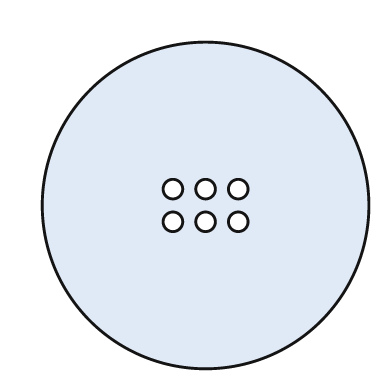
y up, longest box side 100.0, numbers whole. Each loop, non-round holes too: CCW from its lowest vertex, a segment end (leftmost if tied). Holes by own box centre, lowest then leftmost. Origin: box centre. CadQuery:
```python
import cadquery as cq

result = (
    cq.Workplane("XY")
    .moveTo(0.0, 0.0)
    .circle(50.0)
    .moveTo(-10.0, -5.0)
    .circle(3.0)
    .moveTo(0.0, -5.0)
    .circle(3.0)
    .moveTo(10.0, -5.0)
    .circle(3.0)
    .moveTo(-10.0, 5.0)
    .circle(3.0)
    .moveTo(0.0, 5.0)
    .circle(3.0)
    .moveTo(10.0, 5.0)
    .circle(3.0)
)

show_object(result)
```